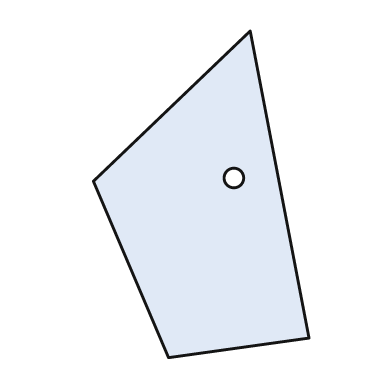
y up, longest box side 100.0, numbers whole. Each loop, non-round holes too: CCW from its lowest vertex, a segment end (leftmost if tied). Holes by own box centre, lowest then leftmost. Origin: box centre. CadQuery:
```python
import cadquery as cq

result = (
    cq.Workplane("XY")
    .moveTo(-10.0, -50.0)
    .lineTo(33.0, -44.0)
    .lineTo(15.0, 50.0)
    .lineTo(-33.0, 4.0)
    .close()
    .moveTo(10.0, 5.0)
    .circle(3.0)
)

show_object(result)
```